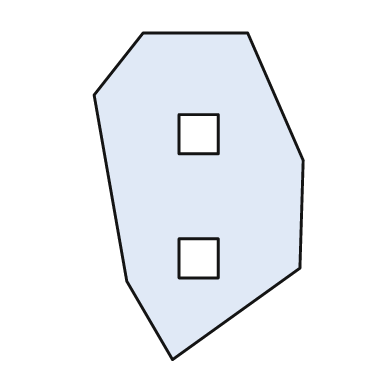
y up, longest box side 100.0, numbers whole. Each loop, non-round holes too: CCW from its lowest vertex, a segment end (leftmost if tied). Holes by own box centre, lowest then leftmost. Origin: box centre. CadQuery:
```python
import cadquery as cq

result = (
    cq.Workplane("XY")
    .moveTo(-8.0, -50.0)
    .lineTo(31.0, -22.0)
    .lineTo(32.0, 11.0)
    .lineTo(15.0, 50.0)
    .lineTo(-17.0, 50.0)
    .lineTo(-32.0, 31.0)
    .lineTo(-22.0, -26.0)
    .close()
    .moveTo(-6.0, -25.0)
    .lineTo(6.0, -25.0)
    .lineTo(6.0, -13.0)
    .lineTo(-6.0, -13.0)
    .close()
    .moveTo(-6.0, 13.0)
    .lineTo(6.0, 13.0)
    .lineTo(6.0, 25.0)
    .lineTo(-6.0, 25.0)
    .close()
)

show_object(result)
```